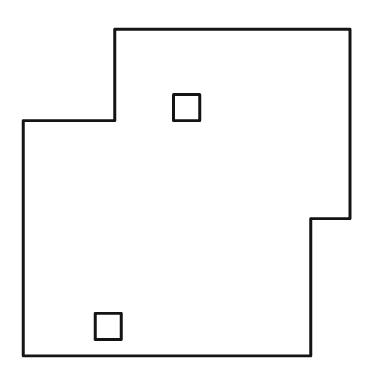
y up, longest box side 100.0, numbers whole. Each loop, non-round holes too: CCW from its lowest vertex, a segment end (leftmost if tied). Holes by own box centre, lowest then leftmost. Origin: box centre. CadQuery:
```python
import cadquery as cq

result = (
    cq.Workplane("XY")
    .moveTo(-50.0, -50.0)
    .lineTo(38.0, -50.0)
    .lineTo(38.0, -8.0)
    .lineTo(50.0, -8.0)
    .lineTo(50.0, 50.0)
    .lineTo(-22.0, 50.0)
    .lineTo(-22.0, 22.0)
    .lineTo(-50.0, 22.0)
    .close()
    .moveTo(-28.0, -45.0)
    .lineTo(-20.0, -45.0)
    .lineTo(-20.0, -37.0)
    .lineTo(-28.0, -37.0)
    .close()
    .moveTo(-4.0, 22.0)
    .lineTo(4.0, 22.0)
    .lineTo(4.0, 30.0)
    .lineTo(-4.0, 30.0)
    .close()
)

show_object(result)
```